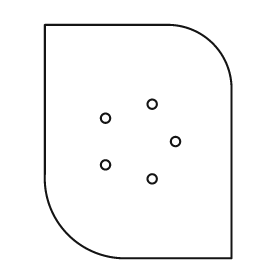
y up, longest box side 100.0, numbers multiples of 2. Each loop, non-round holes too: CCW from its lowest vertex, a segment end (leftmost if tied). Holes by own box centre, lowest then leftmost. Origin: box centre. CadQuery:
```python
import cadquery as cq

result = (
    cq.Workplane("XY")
    .moveTo(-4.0, -50.0)
    .lineTo(40.0, -50.0)
    .lineTo(40.0, 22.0)
    .threePointArc((32.0, 42.0), (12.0, 50.0))
    .lineTo(-40.0, 50.0)
    .lineTo(-40.0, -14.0)
    .threePointArc((-30.0, -40.0), (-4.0, -50.0))
    .close()
    .moveTo(6.0, -16.0)
    .circle(2.0)
    .moveTo(-14.0, -10.0)
    .circle(2.0)
    .moveTo(16.0, 0.0)
    .circle(2.0)
    .moveTo(-14.0, 10.0)
    .circle(2.0)
    .moveTo(6.0, 16.0)
    .circle(2.0)
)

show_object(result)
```